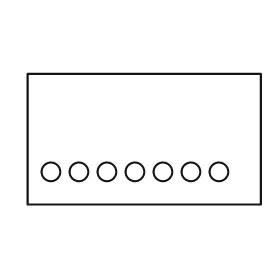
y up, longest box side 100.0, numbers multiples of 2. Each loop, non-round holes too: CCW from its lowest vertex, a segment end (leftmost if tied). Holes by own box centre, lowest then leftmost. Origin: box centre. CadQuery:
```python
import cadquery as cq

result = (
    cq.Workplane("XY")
    .moveTo(-50.0, -28.0)
    .lineTo(50.0, -28.0)
    .lineTo(50.0, 28.0)
    .lineTo(-50.0, 28.0)
    .close()
    .moveTo(-40.0, -14.0)
    .circle(4.0)
    .moveTo(-28.0, -14.0)
    .circle(4.0)
    .moveTo(-16.0, -14.0)
    .circle(4.0)
    .moveTo(-4.0, -14.0)
    .circle(4.0)
    .moveTo(8.0, -14.0)
    .circle(4.0)
    .moveTo(20.0, -14.0)
    .circle(4.0)
    .moveTo(32.0, -14.0)
    .circle(4.0)
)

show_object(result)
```